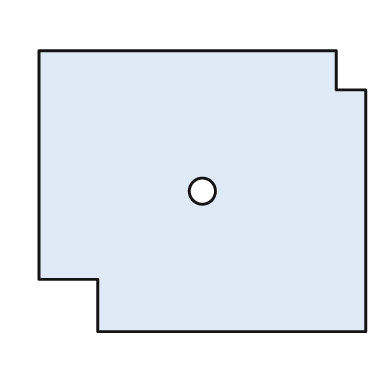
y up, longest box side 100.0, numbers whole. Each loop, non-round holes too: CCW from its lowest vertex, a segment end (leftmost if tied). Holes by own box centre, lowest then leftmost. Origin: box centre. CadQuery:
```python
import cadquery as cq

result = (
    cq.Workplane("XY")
    .moveTo(-32.0, -43.0)
    .lineTo(50.0, -43.0)
    .lineTo(50.0, 31.0)
    .lineTo(41.0, 31.0)
    .lineTo(41.0, 43.0)
    .lineTo(-50.0, 43.0)
    .lineTo(-50.0, -27.0)
    .lineTo(-32.0, -27.0)
    .close()
    .moveTo(0.0, 0.0)
    .circle(4.0)
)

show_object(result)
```